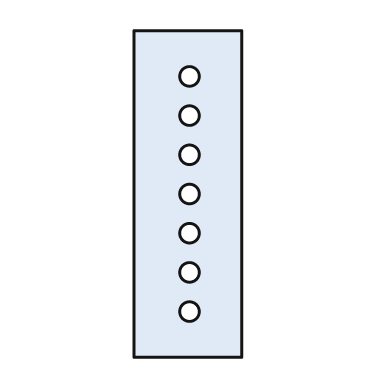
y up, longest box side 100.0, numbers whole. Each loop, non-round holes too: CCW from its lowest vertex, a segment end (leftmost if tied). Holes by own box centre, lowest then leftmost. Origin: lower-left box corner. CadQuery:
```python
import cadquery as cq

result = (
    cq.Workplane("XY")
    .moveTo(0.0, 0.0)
    .lineTo(33.0, 0.0)
    .lineTo(33.0, 100.0)
    .lineTo(0.0, 100.0)
    .close()
    .moveTo(17.0, 14.0)
    .circle(3.0)
    .moveTo(17.0, 26.0)
    .circle(3.0)
    .moveTo(17.0, 38.0)
    .circle(3.0)
    .moveTo(17.0, 50.0)
    .circle(3.0)
    .moveTo(17.0, 62.0)
    .circle(3.0)
    .moveTo(17.0, 74.0)
    .circle(3.0)
    .moveTo(17.0, 86.0)
    .circle(3.0)
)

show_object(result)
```